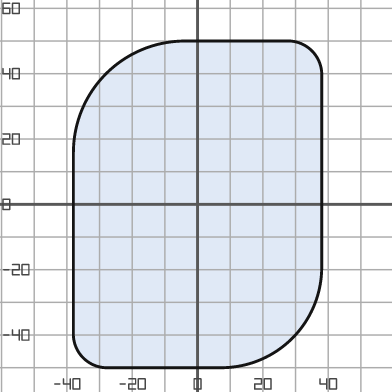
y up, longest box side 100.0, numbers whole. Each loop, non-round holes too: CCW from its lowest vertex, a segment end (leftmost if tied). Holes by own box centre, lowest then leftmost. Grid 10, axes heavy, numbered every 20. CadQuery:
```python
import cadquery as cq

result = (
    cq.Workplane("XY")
    .moveTo(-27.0, -50.0)
    .lineTo(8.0, -50.0)
    .threePointArc((29.0, -41.0), (38.0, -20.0))
    .lineTo(38.0, 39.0)
    .threePointArc((35.0, 47.0), (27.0, 50.0))
    .lineTo(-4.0, 50.0)
    .threePointArc((-28.0, 40.0), (-38.0, 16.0))
    .lineTo(-38.0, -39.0)
    .threePointArc((-35.0, -47.0), (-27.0, -50.0))
    .close()
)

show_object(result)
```